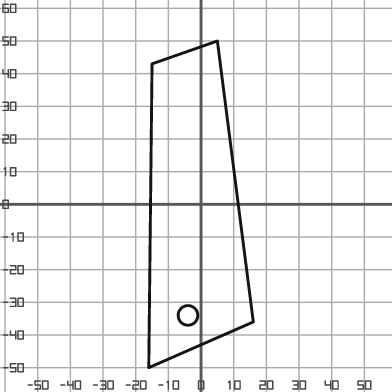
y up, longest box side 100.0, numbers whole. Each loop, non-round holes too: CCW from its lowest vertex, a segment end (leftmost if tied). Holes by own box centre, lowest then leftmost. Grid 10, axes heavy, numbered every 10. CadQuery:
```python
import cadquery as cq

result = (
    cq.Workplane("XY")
    .moveTo(-16.0, -50.0)
    .lineTo(16.0, -36.0)
    .lineTo(5.0, 50.0)
    .lineTo(-15.0, 43.0)
    .close()
    .moveTo(-4.0, -34.0)
    .circle(3.0)
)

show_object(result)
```